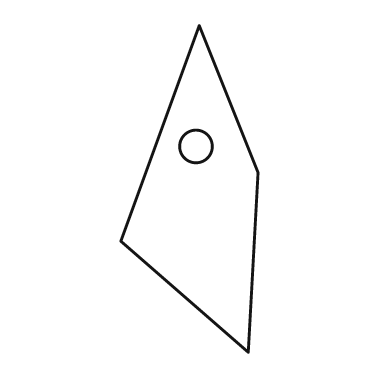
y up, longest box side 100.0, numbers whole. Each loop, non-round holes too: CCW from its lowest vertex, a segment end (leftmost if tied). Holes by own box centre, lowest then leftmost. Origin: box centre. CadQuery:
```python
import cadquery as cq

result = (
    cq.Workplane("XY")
    .moveTo(18.0, -50.0)
    .lineTo(21.0, 5.0)
    .lineTo(3.0, 50.0)
    .lineTo(-21.0, -16.0)
    .close()
    .moveTo(2.0, 13.0)
    .circle(5.0)
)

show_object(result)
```